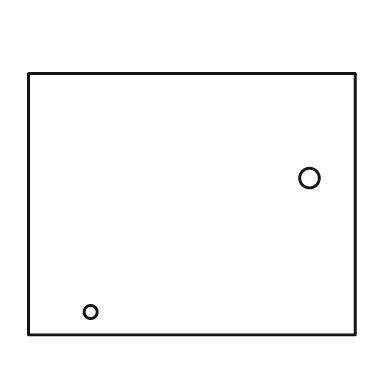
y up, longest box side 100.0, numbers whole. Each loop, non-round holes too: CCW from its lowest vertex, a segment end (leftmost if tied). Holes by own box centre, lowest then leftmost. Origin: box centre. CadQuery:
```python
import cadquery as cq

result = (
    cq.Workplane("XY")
    .moveTo(-50.0, -40.0)
    .lineTo(50.0, -40.0)
    .lineTo(50.0, 40.0)
    .lineTo(-50.0, 40.0)
    .close()
    .moveTo(-31.0, -33.0)
    .circle(2.0)
    .moveTo(36.0, 8.0)
    .circle(3.0)
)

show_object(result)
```